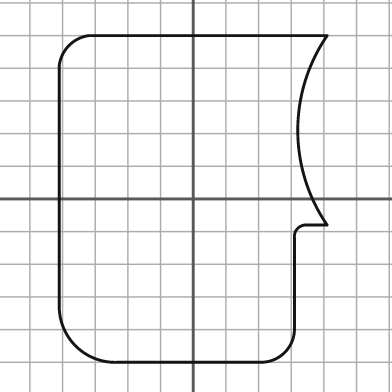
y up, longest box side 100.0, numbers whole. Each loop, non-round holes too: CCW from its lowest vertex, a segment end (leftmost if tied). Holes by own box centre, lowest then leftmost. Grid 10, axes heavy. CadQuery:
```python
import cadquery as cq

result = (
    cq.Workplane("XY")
    .moveTo(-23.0, -50.0)
    .lineTo(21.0, -50.0)
    .threePointArc((28.0, -47.0), (31.0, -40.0))
    .lineTo(31.0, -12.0)
    .threePointArc((32.0, -9.0), (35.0, -8.0))
    .lineTo(41.0, -8.0)
    .threePointArc((32.0, 21.0), (41.0, 50.0))
    .lineTo(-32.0, 50.0)
    .threePointArc((-38.0, 47.0), (-41.0, 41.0))
    .lineTo(-41.0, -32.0)
    .threePointArc((-36.0, -45.0), (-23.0, -50.0))
    .close()
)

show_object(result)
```